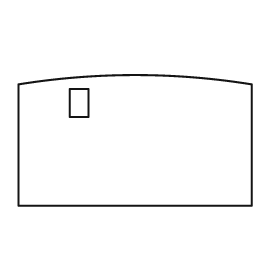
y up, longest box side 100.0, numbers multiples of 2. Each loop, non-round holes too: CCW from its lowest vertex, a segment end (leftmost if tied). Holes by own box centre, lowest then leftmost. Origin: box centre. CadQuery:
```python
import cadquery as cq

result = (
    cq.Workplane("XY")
    .moveTo(-50.0, -28.0)
    .lineTo(50.0, -28.0)
    .lineTo(50.0, 24.0)
    .threePointArc((0.0, 28.0), (-50.0, 24.0))
    .close()
    .moveTo(-28.0, 10.0)
    .lineTo(-20.0, 10.0)
    .lineTo(-20.0, 22.0)
    .lineTo(-28.0, 22.0)
    .close()
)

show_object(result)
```